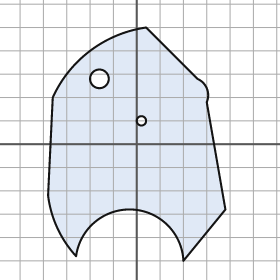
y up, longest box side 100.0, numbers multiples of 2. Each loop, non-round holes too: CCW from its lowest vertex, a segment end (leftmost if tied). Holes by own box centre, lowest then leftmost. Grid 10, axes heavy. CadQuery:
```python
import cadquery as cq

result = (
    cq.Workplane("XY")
    .moveTo(20.0, -50.0)
    .lineTo(38.0, -28.0)
    .lineTo(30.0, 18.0)
    .threePointArc((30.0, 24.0), (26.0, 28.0))
    .lineTo(4.0, 50.0)
    .threePointArc((-20.0, 40.0), (-36.0, 20.0))
    .lineTo(-38.0, -22.0)
    .threePointArc((-34.0, -36.0), (-26.0, -48.0))
    .threePointArc((-2.0, -28.0), (20.0, -50.0))
    .close()
    .moveTo(2.0, 10.0)
    .circle(2.0)
    .moveTo(-16.0, 28.0)
    .circle(4.0)
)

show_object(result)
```